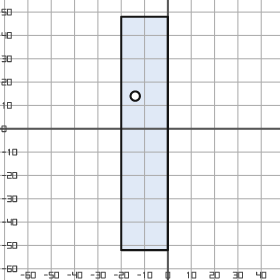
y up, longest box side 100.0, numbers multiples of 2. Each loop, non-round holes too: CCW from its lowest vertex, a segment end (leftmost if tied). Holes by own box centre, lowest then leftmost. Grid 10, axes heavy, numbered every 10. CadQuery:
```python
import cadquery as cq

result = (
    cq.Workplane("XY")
    .moveTo(-20.0, -52.0)
    .lineTo(0.0, -52.0)
    .lineTo(0.0, 48.0)
    .lineTo(-20.0, 48.0)
    .close()
    .moveTo(-14.0, 14.0)
    .circle(2.0)
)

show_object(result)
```